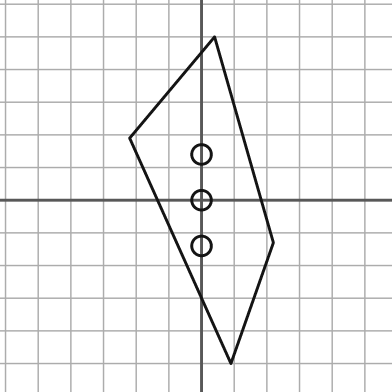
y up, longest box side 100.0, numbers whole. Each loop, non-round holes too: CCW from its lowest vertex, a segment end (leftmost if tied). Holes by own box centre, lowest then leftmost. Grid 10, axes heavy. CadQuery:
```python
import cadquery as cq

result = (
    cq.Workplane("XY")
    .moveTo(9.0, -50.0)
    .lineTo(22.0, -13.0)
    .lineTo(4.0, 50.0)
    .lineTo(-22.0, 19.0)
    .close()
    .moveTo(0.0, -14.0)
    .circle(3.0)
    .moveTo(0.0, 0.0)
    .circle(3.0)
    .moveTo(0.0, 14.0)
    .circle(3.0)
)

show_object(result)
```